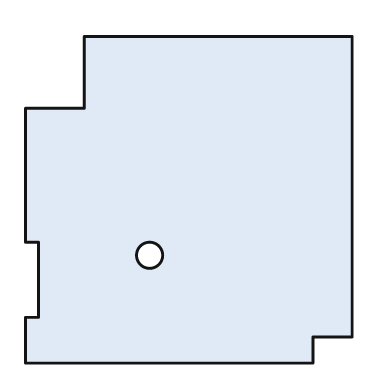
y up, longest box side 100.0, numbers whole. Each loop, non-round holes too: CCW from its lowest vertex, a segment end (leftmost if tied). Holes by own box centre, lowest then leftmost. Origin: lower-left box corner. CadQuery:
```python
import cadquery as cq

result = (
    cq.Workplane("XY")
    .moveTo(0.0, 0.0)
    .lineTo(88.0, 0.0)
    .lineTo(88.0, 8.0)
    .lineTo(100.0, 8.0)
    .lineTo(100.0, 100.0)
    .lineTo(18.0, 100.0)
    .lineTo(18.0, 78.0)
    .lineTo(0.0, 78.0)
    .lineTo(0.0, 37.0)
    .lineTo(4.0, 37.0)
    .lineTo(4.0, 14.0)
    .lineTo(0.0, 14.0)
    .close()
    .moveTo(38.0, 33.0)
    .circle(4.0)
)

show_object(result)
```